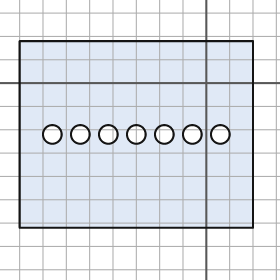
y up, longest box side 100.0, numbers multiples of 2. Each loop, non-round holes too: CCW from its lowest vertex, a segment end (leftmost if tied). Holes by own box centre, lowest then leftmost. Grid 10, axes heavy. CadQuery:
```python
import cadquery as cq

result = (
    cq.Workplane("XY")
    .moveTo(-80.0, -62.0)
    .lineTo(20.0, -62.0)
    .lineTo(20.0, 18.0)
    .lineTo(-80.0, 18.0)
    .close()
    .moveTo(-66.0, -22.0)
    .circle(4.0)
    .moveTo(-54.0, -22.0)
    .circle(4.0)
    .moveTo(-42.0, -22.0)
    .circle(4.0)
    .moveTo(-30.0, -22.0)
    .circle(4.0)
    .moveTo(-18.0, -22.0)
    .circle(4.0)
    .moveTo(-6.0, -22.0)
    .circle(4.0)
    .moveTo(6.0, -22.0)
    .circle(4.0)
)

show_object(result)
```